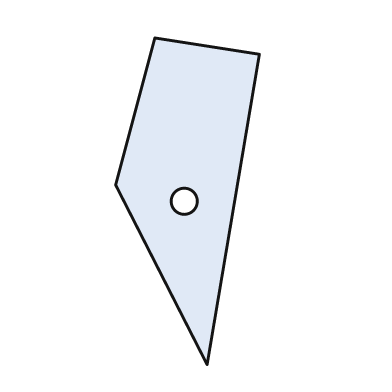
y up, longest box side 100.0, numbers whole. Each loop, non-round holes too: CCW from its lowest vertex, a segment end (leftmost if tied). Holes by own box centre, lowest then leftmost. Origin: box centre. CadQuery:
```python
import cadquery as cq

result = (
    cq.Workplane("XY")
    .moveTo(6.0, -50.0)
    .lineTo(22.0, 45.0)
    .lineTo(-10.0, 50.0)
    .lineTo(-22.0, 5.0)
    .close()
    .moveTo(-1.0, 0.0)
    .circle(4.0)
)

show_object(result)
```